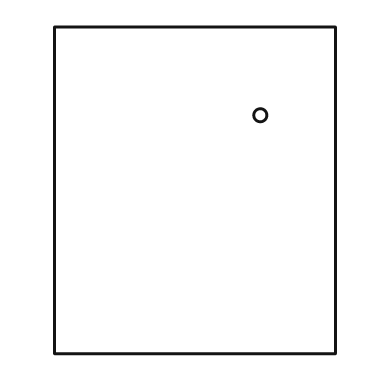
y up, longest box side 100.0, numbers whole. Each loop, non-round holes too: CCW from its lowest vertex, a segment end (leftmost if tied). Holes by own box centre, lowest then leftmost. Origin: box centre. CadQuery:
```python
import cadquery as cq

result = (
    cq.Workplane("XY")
    .moveTo(-43.0, -50.0)
    .lineTo(43.0, -50.0)
    .lineTo(43.0, 50.0)
    .lineTo(-43.0, 50.0)
    .close()
    .moveTo(20.0, 23.0)
    .circle(2.0)
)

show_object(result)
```